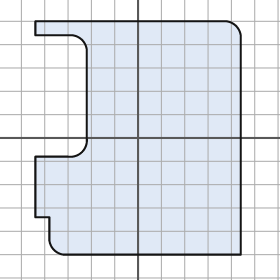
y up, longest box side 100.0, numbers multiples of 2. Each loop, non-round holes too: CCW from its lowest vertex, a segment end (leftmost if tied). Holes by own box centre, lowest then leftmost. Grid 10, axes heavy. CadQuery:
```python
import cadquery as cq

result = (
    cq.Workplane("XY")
    .moveTo(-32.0, -50.0)
    .lineTo(44.0, -50.0)
    .lineTo(44.0, 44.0)
    .threePointArc((42.0, 48.0), (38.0, 50.0))
    .lineTo(-44.0, 50.0)
    .lineTo(-44.0, 44.0)
    .lineTo(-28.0, 44.0)
    .threePointArc((-24.0, 42.0), (-22.0, 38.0))
    .lineTo(-22.0, 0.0)
    .threePointArc((-24.0, -6.0), (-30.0, -8.0))
    .lineTo(-44.0, -8.0)
    .lineTo(-44.0, -34.0)
    .lineTo(-38.0, -34.0)
    .lineTo(-38.0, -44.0)
    .threePointArc((-36.0, -48.0), (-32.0, -50.0))
    .close()
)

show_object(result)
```